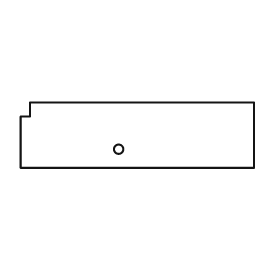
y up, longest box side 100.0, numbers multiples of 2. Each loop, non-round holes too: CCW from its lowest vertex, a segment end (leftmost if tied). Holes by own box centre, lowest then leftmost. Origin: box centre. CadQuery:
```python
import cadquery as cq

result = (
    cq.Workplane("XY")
    .moveTo(-50.0, -14.0)
    .lineTo(50.0, -14.0)
    .lineTo(50.0, 14.0)
    .lineTo(-46.0, 14.0)
    .lineTo(-46.0, 8.0)
    .lineTo(-50.0, 8.0)
    .close()
    .moveTo(-8.0, -6.0)
    .circle(2.0)
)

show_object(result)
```